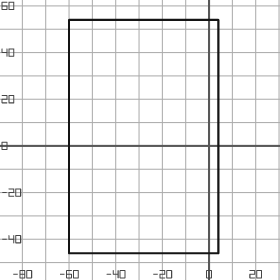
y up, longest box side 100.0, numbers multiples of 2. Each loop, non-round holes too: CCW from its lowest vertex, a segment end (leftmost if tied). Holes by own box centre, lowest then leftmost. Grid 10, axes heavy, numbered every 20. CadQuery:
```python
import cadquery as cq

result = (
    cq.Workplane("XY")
    .moveTo(-60.0, -46.0)
    .lineTo(4.0, -46.0)
    .lineTo(4.0, 54.0)
    .lineTo(-60.0, 54.0)
    .close()
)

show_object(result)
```